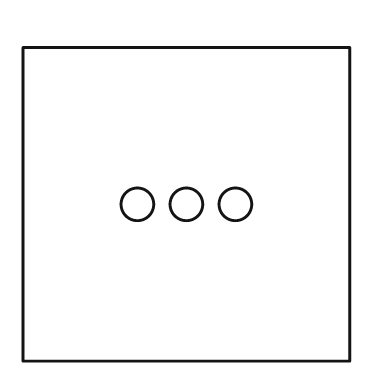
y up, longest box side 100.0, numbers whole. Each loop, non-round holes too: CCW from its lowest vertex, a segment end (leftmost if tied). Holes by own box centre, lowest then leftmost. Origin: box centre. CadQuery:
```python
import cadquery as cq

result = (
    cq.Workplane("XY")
    .moveTo(-50.0, -48.0)
    .lineTo(50.0, -48.0)
    .lineTo(50.0, 48.0)
    .lineTo(-50.0, 48.0)
    .close()
    .moveTo(-15.0, 0.0)
    .circle(5.0)
    .moveTo(0.0, 0.0)
    .circle(5.0)
    .moveTo(15.0, 0.0)
    .circle(5.0)
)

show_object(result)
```